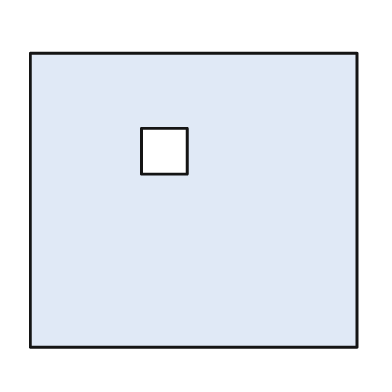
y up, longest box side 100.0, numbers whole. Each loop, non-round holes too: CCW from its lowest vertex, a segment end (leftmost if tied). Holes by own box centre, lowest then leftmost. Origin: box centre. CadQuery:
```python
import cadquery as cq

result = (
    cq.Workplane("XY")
    .moveTo(-50.0, -45.0)
    .lineTo(50.0, -45.0)
    .lineTo(50.0, 45.0)
    .lineTo(-50.0, 45.0)
    .close()
    .moveTo(-16.0, 8.0)
    .lineTo(-2.0, 8.0)
    .lineTo(-2.0, 22.0)
    .lineTo(-16.0, 22.0)
    .close()
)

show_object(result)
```